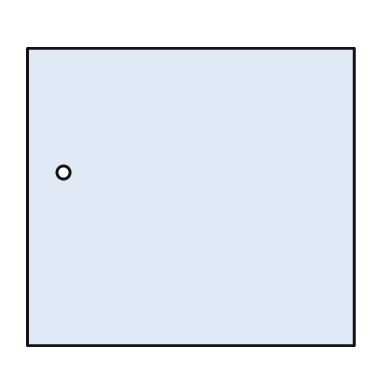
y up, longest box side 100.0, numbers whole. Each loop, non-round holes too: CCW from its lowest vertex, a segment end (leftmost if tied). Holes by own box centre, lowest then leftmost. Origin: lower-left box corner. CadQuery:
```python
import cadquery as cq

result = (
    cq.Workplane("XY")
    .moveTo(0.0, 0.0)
    .lineTo(100.0, 0.0)
    .lineTo(100.0, 91.0)
    .lineTo(0.0, 91.0)
    .close()
    .moveTo(11.0, 53.0)
    .circle(2.0)
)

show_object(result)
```